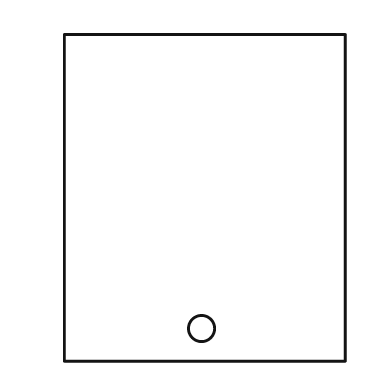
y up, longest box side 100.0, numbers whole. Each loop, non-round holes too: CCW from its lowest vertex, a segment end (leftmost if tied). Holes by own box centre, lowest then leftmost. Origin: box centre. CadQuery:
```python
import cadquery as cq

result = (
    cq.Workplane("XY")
    .moveTo(-43.0, -50.0)
    .lineTo(43.0, -50.0)
    .lineTo(43.0, 50.0)
    .lineTo(-43.0, 50.0)
    .close()
    .moveTo(-1.0, -40.0)
    .circle(4.0)
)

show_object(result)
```